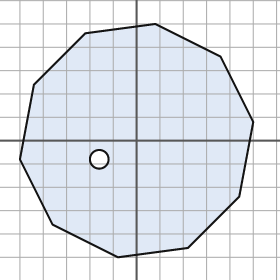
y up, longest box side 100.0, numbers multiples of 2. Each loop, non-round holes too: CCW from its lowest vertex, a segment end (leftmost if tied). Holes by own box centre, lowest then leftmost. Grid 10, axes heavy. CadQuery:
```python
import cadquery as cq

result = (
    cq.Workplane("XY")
    .moveTo(-8.0, -50.0)
    .lineTo(22.0, -46.0)
    .lineTo(44.0, -24.0)
    .lineTo(50.0, 8.0)
    .lineTo(36.0, 36.0)
    .lineTo(8.0, 50.0)
    .lineTo(-22.0, 46.0)
    .lineTo(-44.0, 24.0)
    .lineTo(-50.0, -8.0)
    .lineTo(-36.0, -36.0)
    .close()
    .moveTo(-16.0, -8.0)
    .circle(4.0)
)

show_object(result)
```